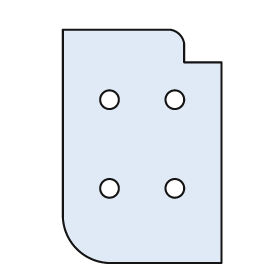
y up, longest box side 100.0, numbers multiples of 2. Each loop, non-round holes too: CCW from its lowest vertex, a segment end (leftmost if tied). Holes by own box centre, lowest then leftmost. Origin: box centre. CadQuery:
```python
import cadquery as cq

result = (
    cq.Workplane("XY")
    .moveTo(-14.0, -50.0)
    .lineTo(34.0, -50.0)
    .lineTo(34.0, 36.0)
    .lineTo(18.0, 36.0)
    .lineTo(18.0, 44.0)
    .threePointArc((16.0, 48.0), (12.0, 50.0))
    .lineTo(-34.0, 50.0)
    .lineTo(-34.0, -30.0)
    .threePointArc((-28.0, -44.0), (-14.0, -50.0))
    .close()
    .moveTo(-14.0, -18.0)
    .circle(4.0)
    .moveTo(14.0, -18.0)
    .circle(4.0)
    .moveTo(-14.0, 20.0)
    .circle(4.0)
    .moveTo(14.0, 20.0)
    .circle(4.0)
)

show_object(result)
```